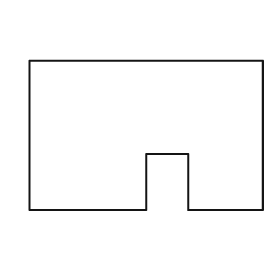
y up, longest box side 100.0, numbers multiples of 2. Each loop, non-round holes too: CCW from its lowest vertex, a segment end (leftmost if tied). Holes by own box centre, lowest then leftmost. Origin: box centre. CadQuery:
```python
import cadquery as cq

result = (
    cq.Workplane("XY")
    .moveTo(-50.0, -32.0)
    .lineTo(0.0, -32.0)
    .lineTo(0.0, -8.0)
    .lineTo(18.0, -8.0)
    .lineTo(18.0, -32.0)
    .lineTo(50.0, -32.0)
    .lineTo(50.0, 32.0)
    .lineTo(-50.0, 32.0)
    .close()
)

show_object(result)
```